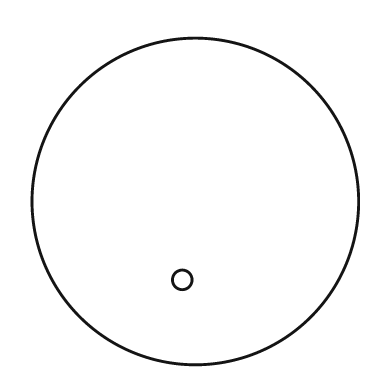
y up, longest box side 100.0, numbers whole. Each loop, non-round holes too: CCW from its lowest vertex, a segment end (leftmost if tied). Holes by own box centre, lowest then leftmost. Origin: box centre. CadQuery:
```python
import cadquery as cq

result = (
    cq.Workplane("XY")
    .moveTo(0.0, 0.0)
    .circle(50.0)
    .moveTo(-4.0, -24.0)
    .circle(3.0)
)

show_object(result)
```